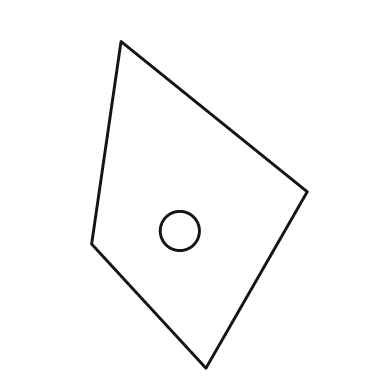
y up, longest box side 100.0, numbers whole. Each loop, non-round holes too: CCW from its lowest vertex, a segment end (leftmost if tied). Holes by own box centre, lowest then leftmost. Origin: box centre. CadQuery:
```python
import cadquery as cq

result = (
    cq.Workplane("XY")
    .moveTo(2.0, -50.0)
    .lineTo(33.0, 4.0)
    .lineTo(-24.0, 50.0)
    .lineTo(-33.0, -12.0)
    .close()
    .moveTo(-6.0, -8.0)
    .circle(6.0)
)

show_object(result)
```